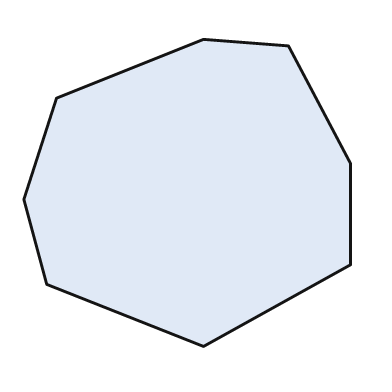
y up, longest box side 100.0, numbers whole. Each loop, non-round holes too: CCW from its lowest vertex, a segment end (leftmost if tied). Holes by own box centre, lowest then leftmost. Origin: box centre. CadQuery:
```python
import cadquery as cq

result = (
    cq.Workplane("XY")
    .moveTo(5.0, -47.0)
    .lineTo(50.0, -22.0)
    .lineTo(50.0, 9.0)
    .lineTo(31.0, 45.0)
    .lineTo(5.0, 47.0)
    .lineTo(-40.0, 29.0)
    .lineTo(-50.0, -2.0)
    .lineTo(-43.0, -28.0)
    .close()
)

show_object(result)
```